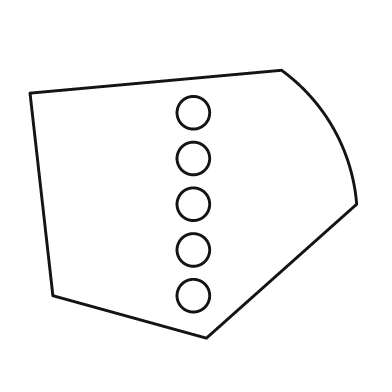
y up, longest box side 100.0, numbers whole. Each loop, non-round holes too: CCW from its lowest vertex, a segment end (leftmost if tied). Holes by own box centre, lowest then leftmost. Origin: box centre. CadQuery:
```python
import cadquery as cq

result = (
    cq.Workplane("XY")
    .moveTo(4.0, -41.0)
    .lineTo(50.0, 0.0)
    .threePointArc((43.0, 23.0), (27.0, 41.0))
    .lineTo(-50.0, 34.0)
    .lineTo(-43.0, -28.0)
    .close()
    .moveTo(0.0, -28.0)
    .circle(5.0)
    .moveTo(0.0, -14.0)
    .circle(5.0)
    .moveTo(0.0, 0.0)
    .circle(5.0)
    .moveTo(0.0, 14.0)
    .circle(5.0)
    .moveTo(0.0, 28.0)
    .circle(5.0)
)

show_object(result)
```